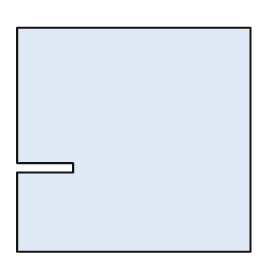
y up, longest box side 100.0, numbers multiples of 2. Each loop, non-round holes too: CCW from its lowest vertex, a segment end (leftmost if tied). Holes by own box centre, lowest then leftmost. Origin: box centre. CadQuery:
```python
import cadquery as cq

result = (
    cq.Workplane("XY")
    .moveTo(-50.0, -48.0)
    .lineTo(50.0, -48.0)
    .lineTo(50.0, 48.0)
    .lineTo(-50.0, 48.0)
    .lineTo(-50.0, -10.0)
    .lineTo(-26.0, -10.0)
    .lineTo(-26.0, -14.0)
    .lineTo(-50.0, -14.0)
    .close()
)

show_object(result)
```